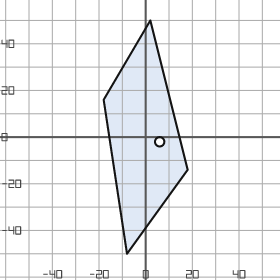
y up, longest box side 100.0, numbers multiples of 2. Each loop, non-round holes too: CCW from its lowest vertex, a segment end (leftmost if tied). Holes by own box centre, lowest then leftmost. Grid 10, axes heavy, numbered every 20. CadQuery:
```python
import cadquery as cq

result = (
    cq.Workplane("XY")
    .moveTo(-8.0, -50.0)
    .lineTo(18.0, -14.0)
    .lineTo(2.0, 50.0)
    .lineTo(-18.0, 16.0)
    .close()
    .moveTo(6.0, -2.0)
    .circle(2.0)
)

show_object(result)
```